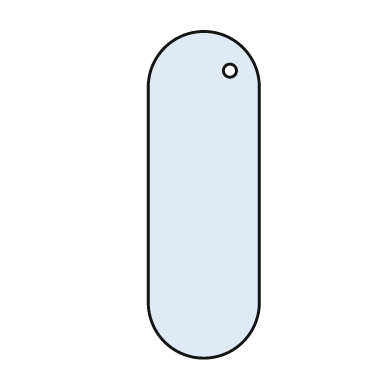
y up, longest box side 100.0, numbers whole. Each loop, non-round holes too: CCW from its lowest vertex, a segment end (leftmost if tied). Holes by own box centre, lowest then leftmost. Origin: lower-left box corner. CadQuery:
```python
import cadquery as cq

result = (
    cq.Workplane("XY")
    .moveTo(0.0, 17.0)
    .threePointArc((17.0, 0.0), (34.0, 17.0))
    .lineTo(34.0, 83.0)
    .threePointArc((17.0, 100.0), (0.0, 83.0))
    .close()
    .moveTo(25.0, 88.0)
    .circle(2.0)
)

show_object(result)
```